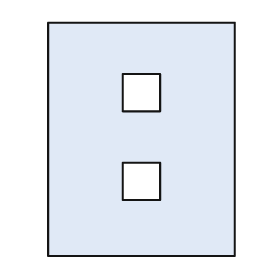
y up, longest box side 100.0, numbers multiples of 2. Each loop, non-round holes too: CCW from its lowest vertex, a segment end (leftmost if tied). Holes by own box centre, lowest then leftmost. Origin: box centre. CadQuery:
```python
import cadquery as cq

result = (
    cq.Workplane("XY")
    .moveTo(-40.0, -50.0)
    .lineTo(40.0, -50.0)
    .lineTo(40.0, 50.0)
    .lineTo(-40.0, 50.0)
    .close()
    .moveTo(-8.0, -26.0)
    .lineTo(8.0, -26.0)
    .lineTo(8.0, -10.0)
    .lineTo(-8.0, -10.0)
    .close()
    .moveTo(-8.0, 12.0)
    .lineTo(8.0, 12.0)
    .lineTo(8.0, 28.0)
    .lineTo(-8.0, 28.0)
    .close()
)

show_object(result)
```